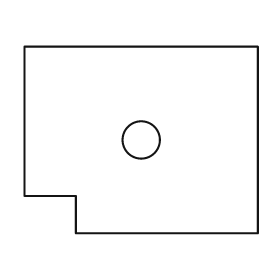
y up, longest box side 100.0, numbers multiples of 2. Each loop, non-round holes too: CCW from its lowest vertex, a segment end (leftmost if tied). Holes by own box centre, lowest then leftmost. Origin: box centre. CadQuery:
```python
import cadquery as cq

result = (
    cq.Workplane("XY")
    .moveTo(-28.0, -40.0)
    .lineTo(50.0, -40.0)
    .lineTo(50.0, 40.0)
    .lineTo(-50.0, 40.0)
    .lineTo(-50.0, -24.0)
    .lineTo(-28.0, -24.0)
    .close()
    .moveTo(0.0, 0.0)
    .circle(8.0)
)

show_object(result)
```